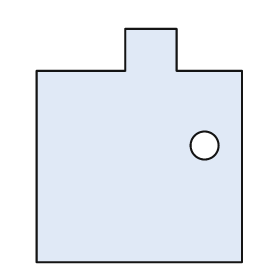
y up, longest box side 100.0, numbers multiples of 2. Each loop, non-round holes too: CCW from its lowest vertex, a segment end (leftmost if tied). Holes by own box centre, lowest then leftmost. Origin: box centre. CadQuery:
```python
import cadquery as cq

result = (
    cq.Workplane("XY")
    .moveTo(-44.0, -50.0)
    .lineTo(44.0, -50.0)
    .lineTo(44.0, 32.0)
    .lineTo(16.0, 32.0)
    .lineTo(16.0, 50.0)
    .lineTo(-6.0, 50.0)
    .lineTo(-6.0, 32.0)
    .lineTo(-44.0, 32.0)
    .close()
    .moveTo(28.0, 0.0)
    .circle(6.0)
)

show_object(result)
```